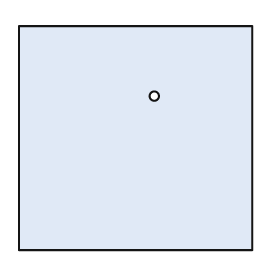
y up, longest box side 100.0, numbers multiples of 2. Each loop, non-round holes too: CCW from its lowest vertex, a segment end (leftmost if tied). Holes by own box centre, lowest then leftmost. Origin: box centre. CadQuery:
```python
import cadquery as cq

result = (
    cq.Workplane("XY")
    .moveTo(-50.0, -48.0)
    .lineTo(50.0, -48.0)
    .lineTo(50.0, 48.0)
    .lineTo(-50.0, 48.0)
    .close()
    .moveTo(8.0, 18.0)
    .circle(2.0)
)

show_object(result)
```